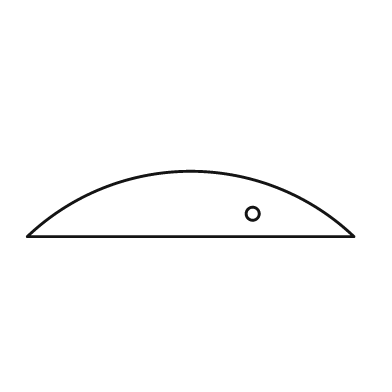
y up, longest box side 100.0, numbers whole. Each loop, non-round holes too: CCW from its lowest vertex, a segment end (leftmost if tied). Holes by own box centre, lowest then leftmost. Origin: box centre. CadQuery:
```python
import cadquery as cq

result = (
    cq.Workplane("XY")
    .moveTo(-50.0, -10.0)
    .lineTo(50.0, -10.0)
    .threePointArc((0.0, 10.0), (-50.0, -10.0))
    .close()
    .moveTo(19.0, -3.0)
    .circle(2.0)
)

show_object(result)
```